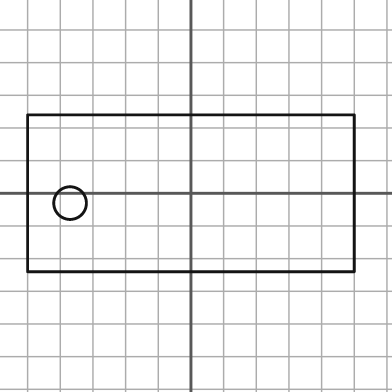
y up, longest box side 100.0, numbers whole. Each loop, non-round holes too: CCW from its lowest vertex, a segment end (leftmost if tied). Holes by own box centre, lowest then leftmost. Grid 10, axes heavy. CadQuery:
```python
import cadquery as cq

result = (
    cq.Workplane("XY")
    .moveTo(-50.0, -24.0)
    .lineTo(50.0, -24.0)
    .lineTo(50.0, 24.0)
    .lineTo(-50.0, 24.0)
    .close()
    .moveTo(-37.0, -3.0)
    .circle(5.0)
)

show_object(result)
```